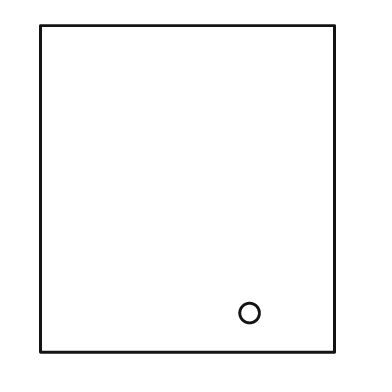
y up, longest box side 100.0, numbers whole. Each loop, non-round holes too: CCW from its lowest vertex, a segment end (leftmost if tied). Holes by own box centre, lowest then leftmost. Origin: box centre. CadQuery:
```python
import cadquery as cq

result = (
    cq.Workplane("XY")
    .moveTo(-45.0, -50.0)
    .lineTo(45.0, -50.0)
    .lineTo(45.0, 50.0)
    .lineTo(-45.0, 50.0)
    .close()
    .moveTo(19.0, -38.0)
    .circle(3.0)
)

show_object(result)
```